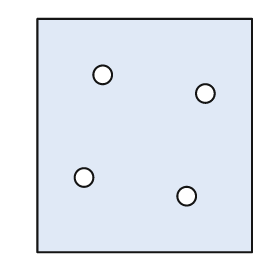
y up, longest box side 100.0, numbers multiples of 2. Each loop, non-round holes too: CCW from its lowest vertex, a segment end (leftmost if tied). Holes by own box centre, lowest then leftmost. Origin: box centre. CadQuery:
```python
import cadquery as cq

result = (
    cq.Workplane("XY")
    .moveTo(-46.0, -50.0)
    .lineTo(46.0, -50.0)
    .lineTo(46.0, 50.0)
    .lineTo(-46.0, 50.0)
    .close()
    .moveTo(18.0, -26.0)
    .circle(4.0)
    .moveTo(-26.0, -18.0)
    .circle(4.0)
    .moveTo(26.0, 18.0)
    .circle(4.0)
    .moveTo(-18.0, 26.0)
    .circle(4.0)
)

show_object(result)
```